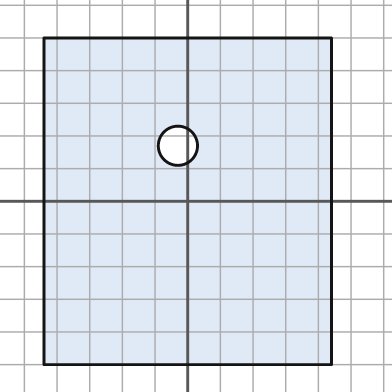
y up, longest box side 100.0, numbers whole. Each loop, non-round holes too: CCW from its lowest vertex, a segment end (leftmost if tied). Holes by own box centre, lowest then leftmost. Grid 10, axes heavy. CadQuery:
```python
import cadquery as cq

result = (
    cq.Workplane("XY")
    .moveTo(-44.0, -50.0)
    .lineTo(44.0, -50.0)
    .lineTo(44.0, 50.0)
    .lineTo(-44.0, 50.0)
    .close()
    .moveTo(-3.0, 17.0)
    .circle(6.0)
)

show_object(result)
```